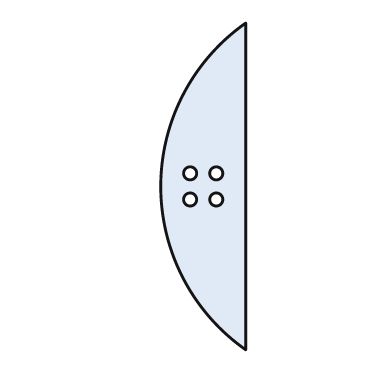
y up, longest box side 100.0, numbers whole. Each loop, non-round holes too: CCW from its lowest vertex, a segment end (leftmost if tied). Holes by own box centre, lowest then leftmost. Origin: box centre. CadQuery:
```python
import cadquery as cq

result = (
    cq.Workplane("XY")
    .moveTo(13.0, -50.0)
    .lineTo(13.0, 50.0)
    .threePointArc((-13.0, 0.0), (13.0, -50.0))
    .close()
    .moveTo(-4.0, -4.0)
    .circle(2.0)
    .moveTo(4.0, -4.0)
    .circle(2.0)
    .moveTo(-4.0, 4.0)
    .circle(2.0)
    .moveTo(4.0, 4.0)
    .circle(2.0)
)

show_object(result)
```